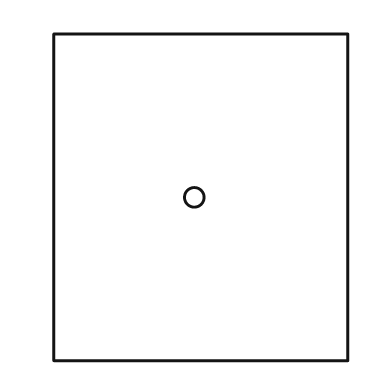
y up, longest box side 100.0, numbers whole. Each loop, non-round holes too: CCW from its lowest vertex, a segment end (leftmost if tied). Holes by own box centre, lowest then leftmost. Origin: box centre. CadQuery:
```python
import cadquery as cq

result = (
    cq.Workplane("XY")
    .moveTo(-45.0, -50.0)
    .lineTo(45.0, -50.0)
    .lineTo(45.0, 50.0)
    .lineTo(-45.0, 50.0)
    .close()
    .moveTo(-2.0, 0.0)
    .circle(3.0)
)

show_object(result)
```